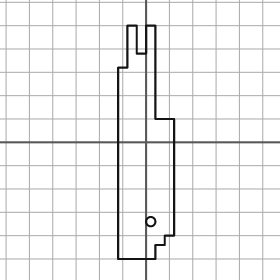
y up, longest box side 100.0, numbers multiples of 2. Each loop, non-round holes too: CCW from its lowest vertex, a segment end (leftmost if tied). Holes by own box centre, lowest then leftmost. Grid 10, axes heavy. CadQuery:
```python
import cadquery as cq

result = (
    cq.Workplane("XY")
    .moveTo(-12.0, -50.0)
    .lineTo(4.0, -50.0)
    .lineTo(4.0, -44.0)
    .lineTo(8.0, -44.0)
    .lineTo(8.0, -40.0)
    .lineTo(12.0, -40.0)
    .lineTo(12.0, 10.0)
    .lineTo(4.0, 10.0)
    .lineTo(4.0, 50.0)
    .lineTo(0.0, 50.0)
    .lineTo(0.0, 38.0)
    .lineTo(-4.0, 38.0)
    .lineTo(-4.0, 50.0)
    .lineTo(-8.0, 50.0)
    .lineTo(-8.0, 32.0)
    .lineTo(-12.0, 32.0)
    .close()
    .moveTo(2.0, -34.0)
    .circle(2.0)
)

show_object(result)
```